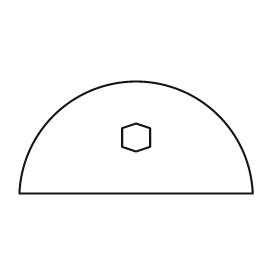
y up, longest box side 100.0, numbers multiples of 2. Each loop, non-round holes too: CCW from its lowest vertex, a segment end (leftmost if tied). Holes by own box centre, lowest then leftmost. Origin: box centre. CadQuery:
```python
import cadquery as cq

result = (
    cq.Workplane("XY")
    .moveTo(-50.0, -24.0)
    .lineTo(50.0, -24.0)
    .threePointArc((0.0, 24.0), (-50.0, -24.0))
    .close()
    .moveTo(0.0, -6.0)
    .lineTo(6.0, -4.0)
    .lineTo(6.0, 4.0)
    .lineTo(0.0, 6.0)
    .lineTo(-6.0, 4.0)
    .lineTo(-6.0, -4.0)
    .close()
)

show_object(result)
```